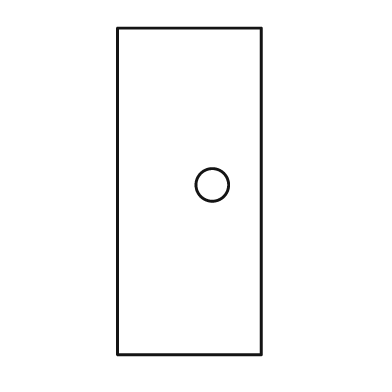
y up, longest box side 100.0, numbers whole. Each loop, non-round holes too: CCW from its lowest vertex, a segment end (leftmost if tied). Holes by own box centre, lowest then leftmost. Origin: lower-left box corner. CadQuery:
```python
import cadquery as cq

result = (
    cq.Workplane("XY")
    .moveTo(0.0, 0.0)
    .lineTo(44.0, 0.0)
    .lineTo(44.0, 100.0)
    .lineTo(0.0, 100.0)
    .close()
    .moveTo(29.0, 52.0)
    .circle(5.0)
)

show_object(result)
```